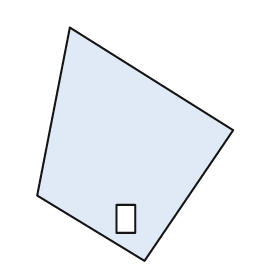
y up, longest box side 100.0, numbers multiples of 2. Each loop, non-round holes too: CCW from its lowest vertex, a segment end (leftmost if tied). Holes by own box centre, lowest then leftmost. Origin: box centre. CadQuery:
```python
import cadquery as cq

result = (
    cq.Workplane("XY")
    .moveTo(4.0, -50.0)
    .lineTo(42.0, 6.0)
    .lineTo(-28.0, 50.0)
    .lineTo(-42.0, -22.0)
    .close()
    .moveTo(-8.0, -38.0)
    .lineTo(0.0, -38.0)
    .lineTo(0.0, -26.0)
    .lineTo(-8.0, -26.0)
    .close()
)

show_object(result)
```